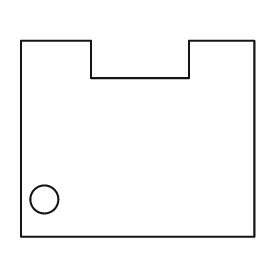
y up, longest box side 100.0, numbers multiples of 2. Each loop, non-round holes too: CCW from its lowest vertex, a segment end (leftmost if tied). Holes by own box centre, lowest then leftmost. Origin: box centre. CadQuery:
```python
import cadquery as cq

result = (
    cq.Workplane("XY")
    .moveTo(-50.0, -42.0)
    .lineTo(50.0, -42.0)
    .lineTo(50.0, 42.0)
    .lineTo(22.0, 42.0)
    .lineTo(22.0, 26.0)
    .lineTo(-20.0, 26.0)
    .lineTo(-20.0, 42.0)
    .lineTo(-50.0, 42.0)
    .close()
    .moveTo(-40.0, -26.0)
    .circle(6.0)
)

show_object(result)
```